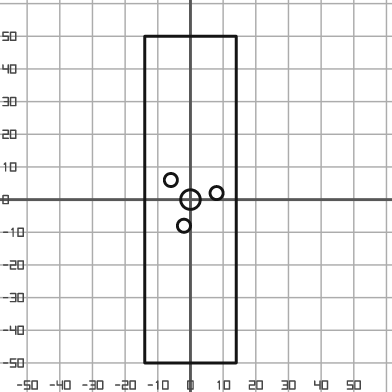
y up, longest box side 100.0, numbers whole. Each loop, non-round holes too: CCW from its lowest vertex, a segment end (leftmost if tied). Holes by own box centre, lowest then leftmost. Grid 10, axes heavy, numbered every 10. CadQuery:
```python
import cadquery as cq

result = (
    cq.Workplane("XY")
    .moveTo(-14.0, -50.0)
    .lineTo(14.0, -50.0)
    .lineTo(14.0, 50.0)
    .lineTo(-14.0, 50.0)
    .close()
    .moveTo(-2.0, -8.0)
    .circle(2.0)
    .moveTo(0.0, 0.0)
    .circle(3.0)
    .moveTo(8.0, 2.0)
    .circle(2.0)
    .moveTo(-6.0, 6.0)
    .circle(2.0)
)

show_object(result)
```